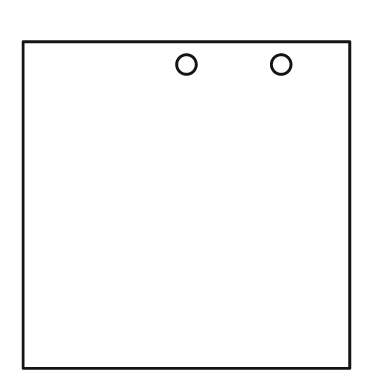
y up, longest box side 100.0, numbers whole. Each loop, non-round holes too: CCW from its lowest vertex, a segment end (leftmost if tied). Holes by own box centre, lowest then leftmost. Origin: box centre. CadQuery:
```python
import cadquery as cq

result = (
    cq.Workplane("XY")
    .moveTo(-50.0, -50.0)
    .lineTo(50.0, -50.0)
    .lineTo(50.0, 50.0)
    .lineTo(-50.0, 50.0)
    .close()
    .moveTo(0.0, 43.0)
    .circle(3.0)
    .moveTo(29.0, 43.0)
    .circle(3.0)
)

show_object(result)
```